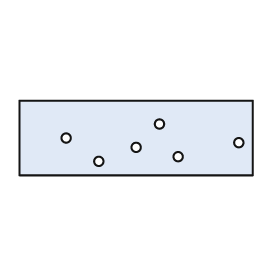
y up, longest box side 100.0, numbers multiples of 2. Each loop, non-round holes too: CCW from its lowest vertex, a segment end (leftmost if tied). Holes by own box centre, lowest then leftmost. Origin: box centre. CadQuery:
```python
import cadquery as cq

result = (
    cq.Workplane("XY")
    .moveTo(-50.0, -16.0)
    .lineTo(50.0, -16.0)
    .lineTo(50.0, 16.0)
    .lineTo(-50.0, 16.0)
    .close()
    .moveTo(-16.0, -10.0)
    .circle(2.0)
    .moveTo(18.0, -8.0)
    .circle(2.0)
    .moveTo(0.0, -4.0)
    .circle(2.0)
    .moveTo(44.0, -2.0)
    .circle(2.0)
    .moveTo(-30.0, 0.0)
    .circle(2.0)
    .moveTo(10.0, 6.0)
    .circle(2.0)
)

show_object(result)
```